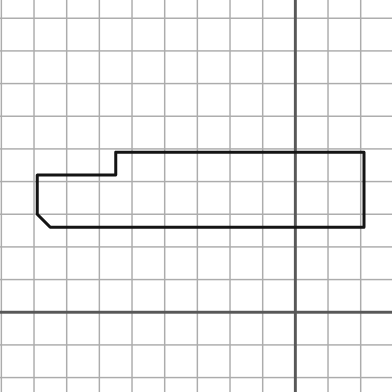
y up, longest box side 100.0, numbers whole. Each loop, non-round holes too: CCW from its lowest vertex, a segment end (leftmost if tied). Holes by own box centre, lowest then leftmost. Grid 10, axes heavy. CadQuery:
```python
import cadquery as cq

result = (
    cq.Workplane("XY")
    .moveTo(-75.0, 26.0)
    .lineTo(21.0, 26.0)
    .lineTo(21.0, 49.0)
    .lineTo(-55.0, 49.0)
    .lineTo(-55.0, 42.0)
    .lineTo(-79.0, 42.0)
    .lineTo(-79.0, 30.0)
    .close()
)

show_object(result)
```